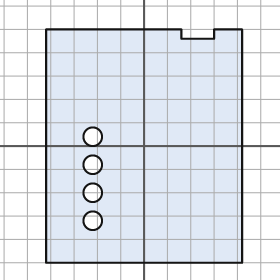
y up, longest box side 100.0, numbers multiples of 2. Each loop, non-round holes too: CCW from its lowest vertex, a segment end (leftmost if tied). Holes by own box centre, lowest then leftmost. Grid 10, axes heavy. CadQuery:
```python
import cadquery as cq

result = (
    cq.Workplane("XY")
    .moveTo(-42.0, -50.0)
    .lineTo(42.0, -50.0)
    .lineTo(42.0, 50.0)
    .lineTo(30.0, 50.0)
    .lineTo(30.0, 46.0)
    .lineTo(16.0, 46.0)
    .lineTo(16.0, 50.0)
    .lineTo(-42.0, 50.0)
    .close()
    .moveTo(-22.0, -32.0)
    .circle(4.0)
    .moveTo(-22.0, -20.0)
    .circle(4.0)
    .moveTo(-22.0, -8.0)
    .circle(4.0)
    .moveTo(-22.0, 4.0)
    .circle(4.0)
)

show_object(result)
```